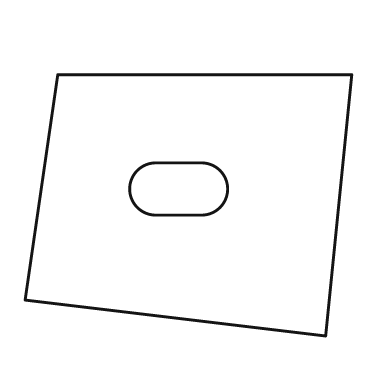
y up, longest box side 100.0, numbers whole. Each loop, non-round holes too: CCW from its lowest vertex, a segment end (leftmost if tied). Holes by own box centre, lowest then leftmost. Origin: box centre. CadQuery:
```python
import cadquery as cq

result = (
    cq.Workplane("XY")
    .moveTo(42.0, -40.0)
    .lineTo(50.0, 40.0)
    .lineTo(-40.0, 40.0)
    .lineTo(-50.0, -29.0)
    .close()
    .moveTo(-10.0, -3.0)
    .lineTo(4.0, -3.0)
    .threePointArc((12.0, 5.0), (4.0, 13.0))
    .lineTo(-10.0, 13.0)
    .threePointArc((-18.0, 5.0), (-10.0, -3.0))
    .close()
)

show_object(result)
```